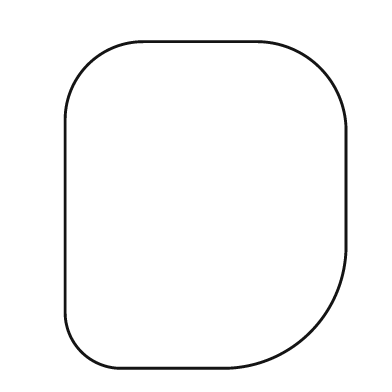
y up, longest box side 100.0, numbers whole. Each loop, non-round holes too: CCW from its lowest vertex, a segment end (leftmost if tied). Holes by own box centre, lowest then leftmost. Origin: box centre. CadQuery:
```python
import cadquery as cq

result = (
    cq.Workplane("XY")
    .moveTo(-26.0, -50.0)
    .lineTo(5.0, -50.0)
    .threePointArc((32.0, -39.0), (43.0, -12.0))
    .lineTo(43.0, 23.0)
    .threePointArc((35.0, 42.0), (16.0, 50.0))
    .lineTo(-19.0, 50.0)
    .threePointArc((-36.0, 43.0), (-43.0, 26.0))
    .lineTo(-43.0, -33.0)
    .threePointArc((-38.0, -45.0), (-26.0, -50.0))
    .close()
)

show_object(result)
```